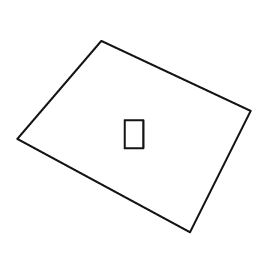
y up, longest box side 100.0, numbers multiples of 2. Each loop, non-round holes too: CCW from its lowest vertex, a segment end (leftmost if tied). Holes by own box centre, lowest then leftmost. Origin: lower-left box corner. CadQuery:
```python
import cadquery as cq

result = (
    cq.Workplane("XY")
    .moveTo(74.0, 0.0)
    .lineTo(100.0, 52.0)
    .lineTo(36.0, 82.0)
    .lineTo(0.0, 40.0)
    .close()
    .moveTo(46.0, 36.0)
    .lineTo(54.0, 36.0)
    .lineTo(54.0, 48.0)
    .lineTo(46.0, 48.0)
    .close()
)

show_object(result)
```